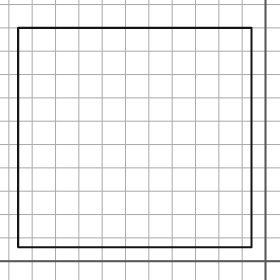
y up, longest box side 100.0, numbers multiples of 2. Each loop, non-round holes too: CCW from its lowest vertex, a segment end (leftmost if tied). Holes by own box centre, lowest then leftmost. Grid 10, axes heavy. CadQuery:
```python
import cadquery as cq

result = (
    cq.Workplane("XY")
    .moveTo(-106.0, 6.0)
    .lineTo(-6.0, 6.0)
    .lineTo(-6.0, 100.0)
    .lineTo(-106.0, 100.0)
    .close()
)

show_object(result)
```